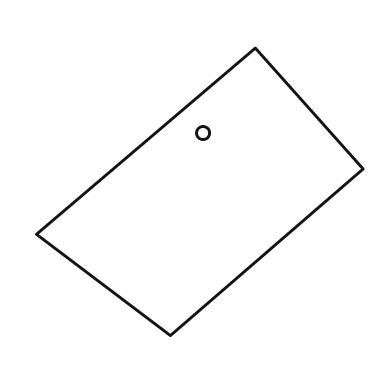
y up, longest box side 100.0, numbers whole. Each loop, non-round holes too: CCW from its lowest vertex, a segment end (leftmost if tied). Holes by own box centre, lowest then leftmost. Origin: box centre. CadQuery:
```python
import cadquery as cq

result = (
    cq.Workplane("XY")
    .moveTo(-9.0, -44.0)
    .lineTo(50.0, 7.0)
    .lineTo(17.0, 44.0)
    .lineTo(-50.0, -13.0)
    .close()
    .moveTo(1.0, 18.0)
    .circle(2.0)
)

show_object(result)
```